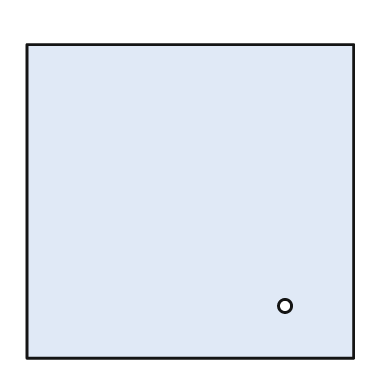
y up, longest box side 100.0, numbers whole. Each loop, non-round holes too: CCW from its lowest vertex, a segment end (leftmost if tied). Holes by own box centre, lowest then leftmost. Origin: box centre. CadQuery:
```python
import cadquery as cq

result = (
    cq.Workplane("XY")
    .moveTo(-50.0, -48.0)
    .lineTo(50.0, -48.0)
    .lineTo(50.0, 48.0)
    .lineTo(-50.0, 48.0)
    .close()
    .moveTo(29.0, -32.0)
    .circle(2.0)
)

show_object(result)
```